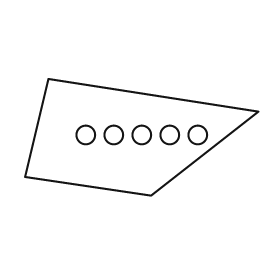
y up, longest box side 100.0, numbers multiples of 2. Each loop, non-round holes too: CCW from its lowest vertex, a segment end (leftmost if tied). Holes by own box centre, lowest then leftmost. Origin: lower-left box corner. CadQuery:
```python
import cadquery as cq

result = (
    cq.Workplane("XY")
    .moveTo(54.0, 0.0)
    .lineTo(100.0, 36.0)
    .lineTo(10.0, 50.0)
    .lineTo(0.0, 8.0)
    .close()
    .moveTo(26.0, 26.0)
    .circle(4.0)
    .moveTo(38.0, 26.0)
    .circle(4.0)
    .moveTo(50.0, 26.0)
    .circle(4.0)
    .moveTo(62.0, 26.0)
    .circle(4.0)
    .moveTo(74.0, 26.0)
    .circle(4.0)
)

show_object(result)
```